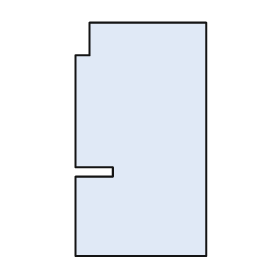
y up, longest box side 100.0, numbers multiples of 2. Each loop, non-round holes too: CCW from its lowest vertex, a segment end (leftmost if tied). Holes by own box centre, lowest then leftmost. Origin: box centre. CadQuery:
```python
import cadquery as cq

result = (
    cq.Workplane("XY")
    .moveTo(-28.0, -50.0)
    .lineTo(28.0, -50.0)
    .lineTo(28.0, 50.0)
    .lineTo(-22.0, 50.0)
    .lineTo(-22.0, 36.0)
    .lineTo(-28.0, 36.0)
    .lineTo(-28.0, -12.0)
    .lineTo(-12.0, -12.0)
    .lineTo(-12.0, -16.0)
    .lineTo(-28.0, -16.0)
    .close()
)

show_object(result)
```